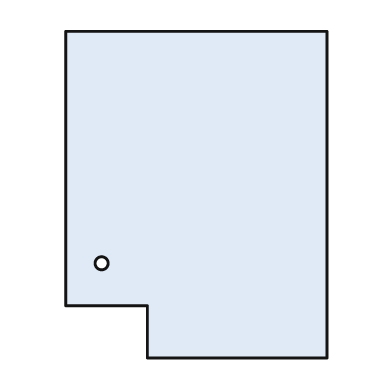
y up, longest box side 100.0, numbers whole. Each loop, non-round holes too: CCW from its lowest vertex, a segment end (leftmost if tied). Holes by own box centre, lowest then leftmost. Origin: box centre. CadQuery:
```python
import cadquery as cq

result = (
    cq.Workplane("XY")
    .moveTo(-15.0, -50.0)
    .lineTo(40.0, -50.0)
    .lineTo(40.0, 50.0)
    .lineTo(-40.0, 50.0)
    .lineTo(-40.0, -34.0)
    .lineTo(-15.0, -34.0)
    .close()
    .moveTo(-29.0, -21.0)
    .circle(2.0)
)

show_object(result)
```